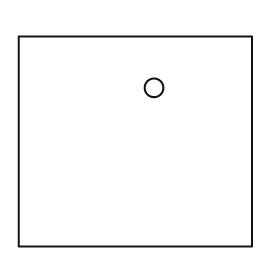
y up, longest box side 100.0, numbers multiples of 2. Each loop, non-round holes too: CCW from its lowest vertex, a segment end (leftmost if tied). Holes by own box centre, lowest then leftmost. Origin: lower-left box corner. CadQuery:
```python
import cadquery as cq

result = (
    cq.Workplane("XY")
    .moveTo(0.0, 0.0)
    .lineTo(100.0, 0.0)
    .lineTo(100.0, 90.0)
    .lineTo(0.0, 90.0)
    .close()
    .moveTo(58.0, 68.0)
    .circle(4.0)
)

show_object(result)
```